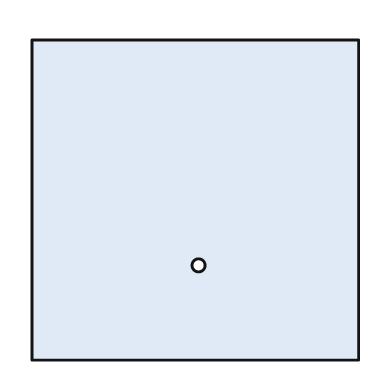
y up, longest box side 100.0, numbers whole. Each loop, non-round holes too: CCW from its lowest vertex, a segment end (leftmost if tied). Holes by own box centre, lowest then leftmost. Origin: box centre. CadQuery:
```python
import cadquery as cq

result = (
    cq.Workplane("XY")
    .moveTo(-50.0, -49.0)
    .lineTo(50.0, -49.0)
    .lineTo(50.0, 49.0)
    .lineTo(-50.0, 49.0)
    .close()
    .moveTo(1.0, -20.0)
    .circle(2.0)
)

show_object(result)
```